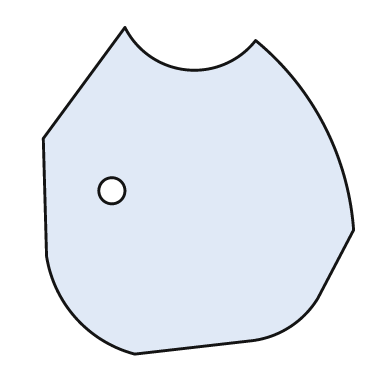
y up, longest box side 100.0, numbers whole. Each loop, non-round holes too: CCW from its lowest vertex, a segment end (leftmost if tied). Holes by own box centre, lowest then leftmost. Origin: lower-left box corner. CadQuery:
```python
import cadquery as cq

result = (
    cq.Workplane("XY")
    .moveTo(28.0, 0.0)
    .lineTo(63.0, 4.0)
    .threePointArc((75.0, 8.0), (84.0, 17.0))
    .lineTo(95.0, 38.0)
    .threePointArc((86.0, 70.0), (65.0, 96.0))
    .threePointArc((44.0, 87.0), (25.0, 100.0))
    .lineTo(0.0, 66.0)
    .lineTo(1.0, 30.0)
    .threePointArc((10.0, 11.0), (28.0, 0.0))
    .close()
    .moveTo(21.0, 50.0)
    .circle(4.0)
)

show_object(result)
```